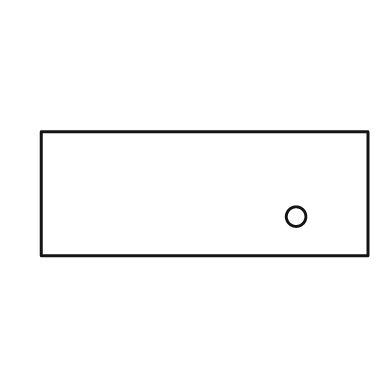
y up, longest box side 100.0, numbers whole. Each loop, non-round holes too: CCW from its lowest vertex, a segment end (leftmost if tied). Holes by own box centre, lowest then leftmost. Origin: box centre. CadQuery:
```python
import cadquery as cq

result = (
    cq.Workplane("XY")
    .moveTo(-50.0, -19.0)
    .lineTo(50.0, -19.0)
    .lineTo(50.0, 19.0)
    .lineTo(-50.0, 19.0)
    .close()
    .moveTo(28.0, -7.0)
    .circle(3.0)
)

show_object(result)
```